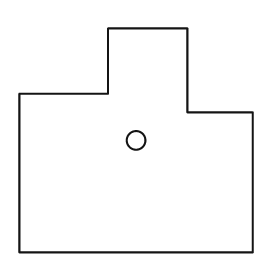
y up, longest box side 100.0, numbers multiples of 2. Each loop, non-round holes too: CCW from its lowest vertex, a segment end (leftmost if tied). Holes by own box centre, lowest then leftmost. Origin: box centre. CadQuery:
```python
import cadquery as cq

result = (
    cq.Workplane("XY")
    .moveTo(-50.0, -48.0)
    .lineTo(50.0, -48.0)
    .lineTo(50.0, 12.0)
    .lineTo(22.0, 12.0)
    .lineTo(22.0, 48.0)
    .lineTo(-12.0, 48.0)
    .lineTo(-12.0, 20.0)
    .lineTo(-50.0, 20.0)
    .close()
    .moveTo(0.0, 0.0)
    .circle(4.0)
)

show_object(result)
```